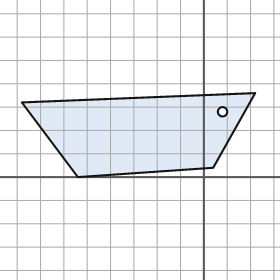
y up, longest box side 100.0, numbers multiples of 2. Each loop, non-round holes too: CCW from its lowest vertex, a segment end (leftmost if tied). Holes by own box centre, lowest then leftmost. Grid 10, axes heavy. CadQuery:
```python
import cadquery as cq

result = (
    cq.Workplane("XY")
    .moveTo(-54.0, 0.0)
    .lineTo(4.0, 4.0)
    .lineTo(22.0, 36.0)
    .lineTo(-78.0, 32.0)
    .close()
    .moveTo(8.0, 28.0)
    .circle(2.0)
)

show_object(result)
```